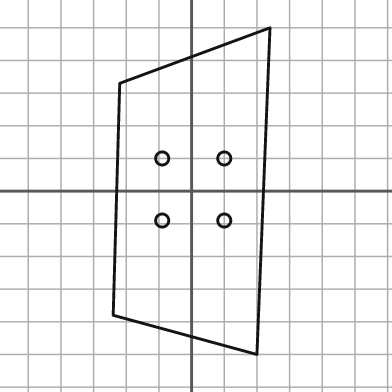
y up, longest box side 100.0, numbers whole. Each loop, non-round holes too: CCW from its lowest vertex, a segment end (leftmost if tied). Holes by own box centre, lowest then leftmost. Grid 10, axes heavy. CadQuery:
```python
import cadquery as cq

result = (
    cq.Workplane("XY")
    .moveTo(20.0, -50.0)
    .lineTo(24.0, 50.0)
    .lineTo(-22.0, 33.0)
    .lineTo(-24.0, -38.0)
    .close()
    .moveTo(-9.0, -9.0)
    .circle(2.0)
    .moveTo(10.0, -9.0)
    .circle(2.0)
    .moveTo(-9.0, 10.0)
    .circle(2.0)
    .moveTo(10.0, 10.0)
    .circle(2.0)
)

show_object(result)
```